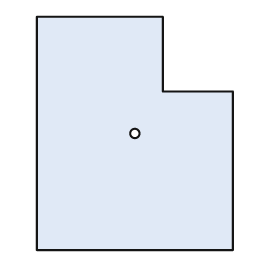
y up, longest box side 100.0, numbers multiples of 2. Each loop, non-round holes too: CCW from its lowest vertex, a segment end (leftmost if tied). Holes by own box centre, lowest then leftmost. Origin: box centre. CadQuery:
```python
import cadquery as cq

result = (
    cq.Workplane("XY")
    .moveTo(-42.0, -50.0)
    .lineTo(42.0, -50.0)
    .lineTo(42.0, 18.0)
    .lineTo(12.0, 18.0)
    .lineTo(12.0, 50.0)
    .lineTo(-42.0, 50.0)
    .close()
    .moveTo(0.0, 0.0)
    .circle(2.0)
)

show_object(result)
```